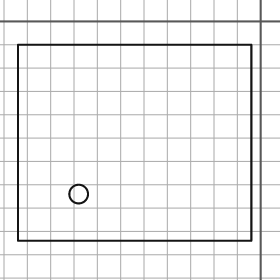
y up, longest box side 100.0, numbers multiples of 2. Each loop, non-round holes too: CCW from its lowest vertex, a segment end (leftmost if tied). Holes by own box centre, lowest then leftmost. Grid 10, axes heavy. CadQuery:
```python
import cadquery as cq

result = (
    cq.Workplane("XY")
    .moveTo(-104.0, -94.0)
    .lineTo(-4.0, -94.0)
    .lineTo(-4.0, -10.0)
    .lineTo(-104.0, -10.0)
    .close()
    .moveTo(-78.0, -74.0)
    .circle(4.0)
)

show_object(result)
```